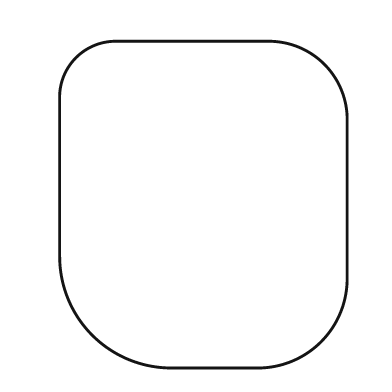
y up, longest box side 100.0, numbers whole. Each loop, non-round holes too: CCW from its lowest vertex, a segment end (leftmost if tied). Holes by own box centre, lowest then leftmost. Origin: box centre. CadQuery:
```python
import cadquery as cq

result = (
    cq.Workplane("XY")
    .moveTo(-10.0, -50.0)
    .lineTo(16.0, -50.0)
    .threePointArc((36.0, -42.0), (44.0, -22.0))
    .lineTo(44.0, 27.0)
    .threePointArc((37.0, 43.0), (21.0, 50.0))
    .lineTo(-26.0, 50.0)
    .threePointArc((-39.0, 45.0), (-44.0, 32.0))
    .lineTo(-44.0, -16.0)
    .threePointArc((-34.0, -40.0), (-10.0, -50.0))
    .close()
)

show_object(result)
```